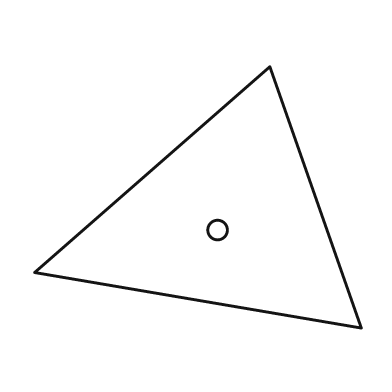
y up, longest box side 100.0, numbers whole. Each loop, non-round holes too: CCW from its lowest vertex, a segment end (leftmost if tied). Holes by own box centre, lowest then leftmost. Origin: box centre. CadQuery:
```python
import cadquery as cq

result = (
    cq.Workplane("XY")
    .moveTo(50.0, -40.0)
    .lineTo(22.0, 40.0)
    .lineTo(-50.0, -23.0)
    .close()
    .moveTo(6.0, -10.0)
    .circle(3.0)
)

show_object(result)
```